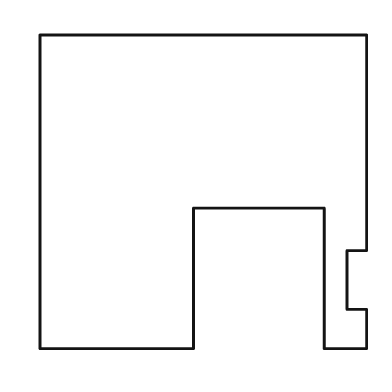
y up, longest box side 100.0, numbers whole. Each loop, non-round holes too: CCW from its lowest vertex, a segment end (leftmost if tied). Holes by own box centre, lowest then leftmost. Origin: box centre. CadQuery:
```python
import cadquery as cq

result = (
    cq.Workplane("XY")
    .moveTo(-50.0, -48.0)
    .lineTo(-3.0, -48.0)
    .lineTo(-3.0, -5.0)
    .lineTo(37.0, -5.0)
    .lineTo(37.0, -48.0)
    .lineTo(50.0, -48.0)
    .lineTo(50.0, -36.0)
    .lineTo(44.0, -36.0)
    .lineTo(44.0, -18.0)
    .lineTo(50.0, -18.0)
    .lineTo(50.0, 48.0)
    .lineTo(-50.0, 48.0)
    .close()
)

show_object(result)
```